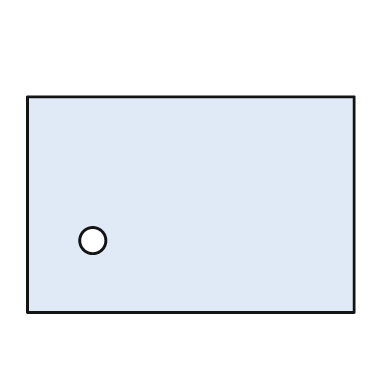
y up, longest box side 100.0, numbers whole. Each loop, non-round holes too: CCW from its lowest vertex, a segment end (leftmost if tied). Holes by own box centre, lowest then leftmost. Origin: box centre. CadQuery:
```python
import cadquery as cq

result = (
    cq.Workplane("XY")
    .moveTo(-50.0, -33.0)
    .lineTo(50.0, -33.0)
    .lineTo(50.0, 33.0)
    .lineTo(-50.0, 33.0)
    .close()
    .moveTo(-30.0, -11.0)
    .circle(4.0)
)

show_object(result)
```